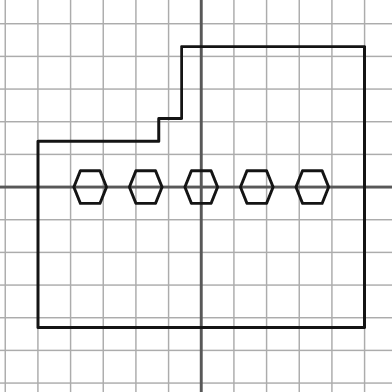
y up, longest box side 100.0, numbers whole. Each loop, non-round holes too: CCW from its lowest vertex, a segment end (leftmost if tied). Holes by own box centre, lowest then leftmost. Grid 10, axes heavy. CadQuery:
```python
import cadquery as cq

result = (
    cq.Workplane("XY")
    .moveTo(-50.0, -43.0)
    .lineTo(50.0, -43.0)
    .lineTo(50.0, 43.0)
    .lineTo(-6.0, 43.0)
    .lineTo(-6.0, 21.0)
    .lineTo(-13.0, 21.0)
    .lineTo(-13.0, 14.0)
    .lineTo(-50.0, 14.0)
    .close()
    .moveTo(-37.0, -5.0)
    .lineTo(-31.0, -5.0)
    .lineTo(-29.0, 0.0)
    .lineTo(-31.0, 5.0)
    .lineTo(-37.0, 5.0)
    .lineTo(-39.0, 0.0)
    .close()
    .moveTo(-20.0, -5.0)
    .lineTo(-14.0, -5.0)
    .lineTo(-12.0, 0.0)
    .lineTo(-14.0, 5.0)
    .lineTo(-20.0, 5.0)
    .lineTo(-22.0, 0.0)
    .close()
    .moveTo(-3.0, -5.0)
    .lineTo(3.0, -5.0)
    .lineTo(5.0, 0.0)
    .lineTo(3.0, 5.0)
    .lineTo(-3.0, 5.0)
    .lineTo(-5.0, 0.0)
    .close()
    .moveTo(14.0, -5.0)
    .lineTo(20.0, -5.0)
    .lineTo(22.0, 0.0)
    .lineTo(20.0, 5.0)
    .lineTo(14.0, 5.0)
    .lineTo(12.0, 0.0)
    .close()
    .moveTo(31.0, -5.0)
    .lineTo(37.0, -5.0)
    .lineTo(39.0, 0.0)
    .lineTo(37.0, 5.0)
    .lineTo(31.0, 5.0)
    .lineTo(29.0, 0.0)
    .close()
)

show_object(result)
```